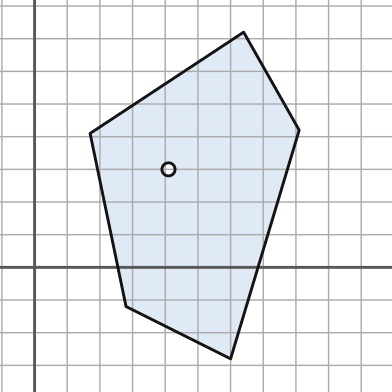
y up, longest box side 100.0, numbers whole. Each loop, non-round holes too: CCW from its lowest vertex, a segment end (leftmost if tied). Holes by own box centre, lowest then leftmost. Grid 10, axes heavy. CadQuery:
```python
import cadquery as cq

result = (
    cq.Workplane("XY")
    .moveTo(60.0, -28.0)
    .lineTo(81.0, 42.0)
    .lineTo(64.0, 72.0)
    .lineTo(17.0, 41.0)
    .lineTo(28.0, -12.0)
    .close()
    .moveTo(41.0, 30.0)
    .circle(2.0)
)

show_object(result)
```